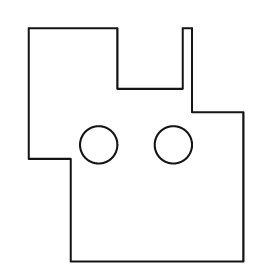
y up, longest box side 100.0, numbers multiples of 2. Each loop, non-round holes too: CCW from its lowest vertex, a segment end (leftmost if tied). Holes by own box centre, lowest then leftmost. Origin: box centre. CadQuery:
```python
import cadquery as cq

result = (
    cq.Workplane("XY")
    .moveTo(-28.0, -50.0)
    .lineTo(46.0, -50.0)
    .lineTo(46.0, 14.0)
    .lineTo(24.0, 14.0)
    .lineTo(24.0, 50.0)
    .lineTo(20.0, 50.0)
    .lineTo(20.0, 24.0)
    .lineTo(-8.0, 24.0)
    .lineTo(-8.0, 50.0)
    .lineTo(-46.0, 50.0)
    .lineTo(-46.0, -6.0)
    .lineTo(-28.0, -6.0)
    .close()
    .moveTo(-16.0, 0.0)
    .circle(8.0)
    .moveTo(16.0, 0.0)
    .circle(8.0)
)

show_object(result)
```